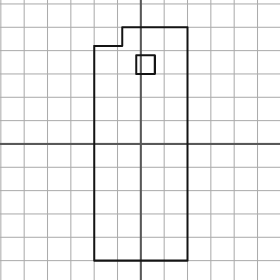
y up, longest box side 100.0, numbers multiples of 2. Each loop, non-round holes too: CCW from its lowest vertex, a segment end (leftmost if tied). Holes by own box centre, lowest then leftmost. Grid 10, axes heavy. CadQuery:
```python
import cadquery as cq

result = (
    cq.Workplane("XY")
    .moveTo(-20.0, -50.0)
    .lineTo(20.0, -50.0)
    .lineTo(20.0, 50.0)
    .lineTo(-8.0, 50.0)
    .lineTo(-8.0, 42.0)
    .lineTo(-20.0, 42.0)
    .close()
    .moveTo(-2.0, 30.0)
    .lineTo(6.0, 30.0)
    .lineTo(6.0, 38.0)
    .lineTo(-2.0, 38.0)
    .close()
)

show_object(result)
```